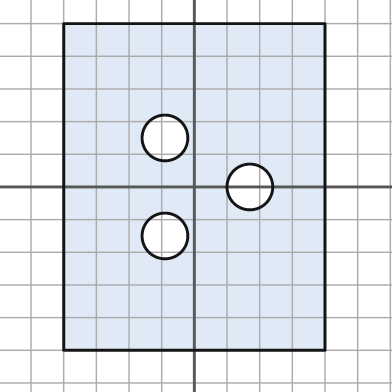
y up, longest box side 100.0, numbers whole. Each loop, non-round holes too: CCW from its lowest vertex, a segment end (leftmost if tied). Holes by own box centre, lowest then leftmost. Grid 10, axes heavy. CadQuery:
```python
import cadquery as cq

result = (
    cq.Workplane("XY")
    .moveTo(-40.0, -50.0)
    .lineTo(40.0, -50.0)
    .lineTo(40.0, 50.0)
    .lineTo(-40.0, 50.0)
    .close()
    .moveTo(-9.0, -15.0)
    .circle(7.0)
    .moveTo(17.0, 0.0)
    .circle(7.0)
    .moveTo(-9.0, 15.0)
    .circle(7.0)
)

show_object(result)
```